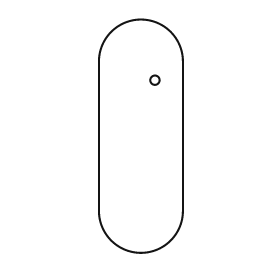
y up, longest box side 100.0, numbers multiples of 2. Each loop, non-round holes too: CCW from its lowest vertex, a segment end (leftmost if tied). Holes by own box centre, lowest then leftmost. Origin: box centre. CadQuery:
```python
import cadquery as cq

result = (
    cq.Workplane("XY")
    .moveTo(-18.0, -32.0)
    .threePointArc((0.0, -50.0), (18.0, -32.0))
    .lineTo(18.0, 32.0)
    .threePointArc((0.0, 50.0), (-18.0, 32.0))
    .close()
    .moveTo(6.0, 24.0)
    .circle(2.0)
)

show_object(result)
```